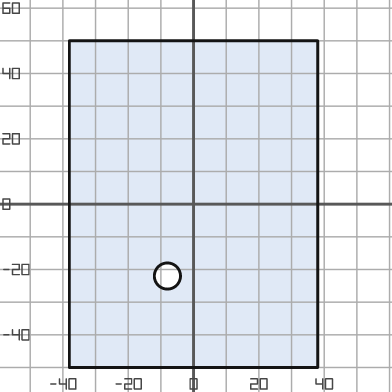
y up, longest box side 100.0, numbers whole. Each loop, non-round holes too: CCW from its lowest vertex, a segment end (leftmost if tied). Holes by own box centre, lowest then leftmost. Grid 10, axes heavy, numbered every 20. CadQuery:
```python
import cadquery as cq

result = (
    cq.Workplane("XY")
    .moveTo(-38.0, -50.0)
    .lineTo(38.0, -50.0)
    .lineTo(38.0, 50.0)
    .lineTo(-38.0, 50.0)
    .close()
    .moveTo(-8.0, -22.0)
    .circle(4.0)
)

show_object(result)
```